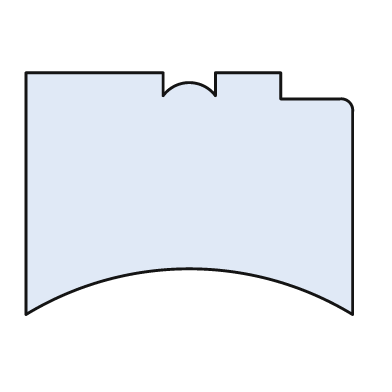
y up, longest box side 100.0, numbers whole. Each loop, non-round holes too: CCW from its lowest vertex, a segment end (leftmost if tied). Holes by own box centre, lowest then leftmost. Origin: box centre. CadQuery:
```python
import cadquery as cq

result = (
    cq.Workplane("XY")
    .moveTo(-50.0, -37.0)
    .threePointArc((0.0, -23.0), (50.0, -37.0))
    .lineTo(50.0, 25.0)
    .threePointArc((49.0, 28.0), (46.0, 29.0))
    .lineTo(28.0, 29.0)
    .lineTo(28.0, 37.0)
    .lineTo(8.0, 37.0)
    .lineTo(8.0, 30.0)
    .threePointArc((0.0, 34.0), (-8.0, 30.0))
    .lineTo(-8.0, 37.0)
    .lineTo(-50.0, 37.0)
    .close()
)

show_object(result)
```